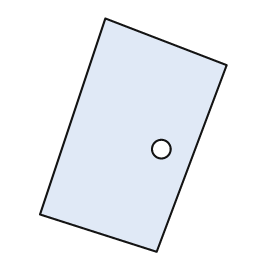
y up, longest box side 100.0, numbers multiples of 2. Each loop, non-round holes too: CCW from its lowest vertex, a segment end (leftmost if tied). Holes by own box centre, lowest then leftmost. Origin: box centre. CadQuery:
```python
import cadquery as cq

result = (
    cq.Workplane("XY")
    .moveTo(10.0, -50.0)
    .lineTo(40.0, 30.0)
    .lineTo(-12.0, 50.0)
    .lineTo(-40.0, -34.0)
    .close()
    .moveTo(12.0, -6.0)
    .circle(4.0)
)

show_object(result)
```